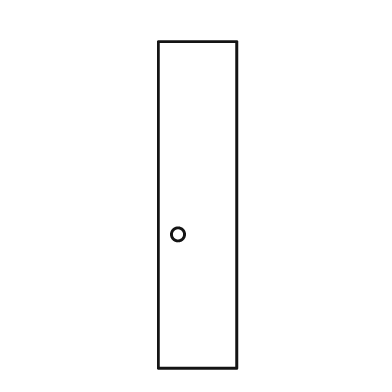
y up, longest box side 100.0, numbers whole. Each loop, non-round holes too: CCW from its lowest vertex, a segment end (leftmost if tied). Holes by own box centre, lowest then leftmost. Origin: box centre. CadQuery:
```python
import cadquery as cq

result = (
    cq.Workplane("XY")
    .moveTo(-12.0, -50.0)
    .lineTo(12.0, -50.0)
    .lineTo(12.0, 50.0)
    .lineTo(-12.0, 50.0)
    .close()
    .moveTo(-6.0, -9.0)
    .circle(2.0)
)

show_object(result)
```